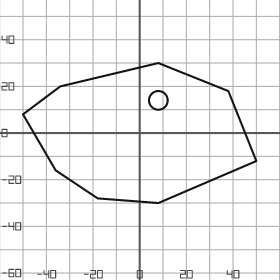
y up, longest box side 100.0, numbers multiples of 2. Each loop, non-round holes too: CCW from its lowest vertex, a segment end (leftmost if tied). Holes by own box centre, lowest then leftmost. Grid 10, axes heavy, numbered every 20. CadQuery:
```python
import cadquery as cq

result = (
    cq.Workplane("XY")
    .moveTo(8.0, -30.0)
    .lineTo(50.0, -12.0)
    .lineTo(38.0, 18.0)
    .lineTo(8.0, 30.0)
    .lineTo(-34.0, 20.0)
    .lineTo(-50.0, 8.0)
    .lineTo(-36.0, -16.0)
    .lineTo(-18.0, -28.0)
    .close()
    .moveTo(8.0, 14.0)
    .circle(4.0)
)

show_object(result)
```